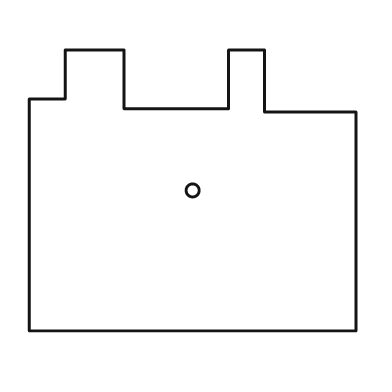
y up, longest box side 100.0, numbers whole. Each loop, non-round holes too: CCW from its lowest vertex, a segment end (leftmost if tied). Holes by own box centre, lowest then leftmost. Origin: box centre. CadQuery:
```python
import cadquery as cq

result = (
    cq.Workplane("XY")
    .moveTo(-50.0, -43.0)
    .lineTo(50.0, -43.0)
    .lineTo(50.0, 24.0)
    .lineTo(22.0, 24.0)
    .lineTo(22.0, 43.0)
    .lineTo(11.0, 43.0)
    .lineTo(11.0, 25.0)
    .lineTo(-21.0, 25.0)
    .lineTo(-21.0, 43.0)
    .lineTo(-39.0, 43.0)
    .lineTo(-39.0, 28.0)
    .lineTo(-50.0, 28.0)
    .close()
    .moveTo(0.0, 0.0)
    .circle(2.0)
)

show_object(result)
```